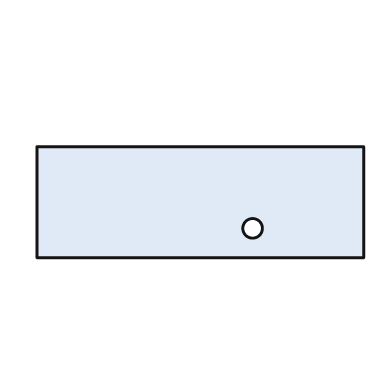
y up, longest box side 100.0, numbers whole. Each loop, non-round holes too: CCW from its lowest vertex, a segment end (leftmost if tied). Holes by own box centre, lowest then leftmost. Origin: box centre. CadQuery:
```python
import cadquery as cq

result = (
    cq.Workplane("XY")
    .moveTo(-50.0, -17.0)
    .lineTo(50.0, -17.0)
    .lineTo(50.0, 17.0)
    .lineTo(-50.0, 17.0)
    .close()
    .moveTo(16.0, -8.0)
    .circle(3.0)
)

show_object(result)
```